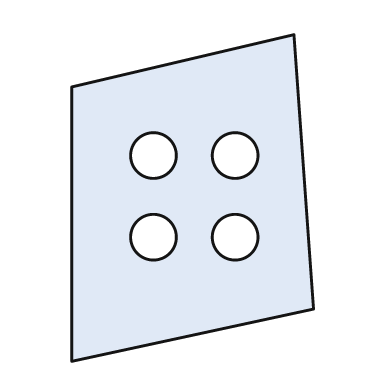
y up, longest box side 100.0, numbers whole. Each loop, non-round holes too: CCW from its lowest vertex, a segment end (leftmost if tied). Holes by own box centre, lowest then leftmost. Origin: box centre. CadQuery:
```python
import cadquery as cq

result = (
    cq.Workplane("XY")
    .moveTo(-37.0, -50.0)
    .lineTo(37.0, -34.0)
    .lineTo(31.0, 50.0)
    .lineTo(-37.0, 34.0)
    .close()
    .moveTo(-12.0, -12.0)
    .circle(7.0)
    .moveTo(13.0, -12.0)
    .circle(7.0)
    .moveTo(-12.0, 13.0)
    .circle(7.0)
    .moveTo(13.0, 13.0)
    .circle(7.0)
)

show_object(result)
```